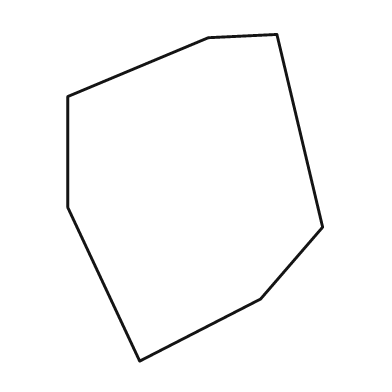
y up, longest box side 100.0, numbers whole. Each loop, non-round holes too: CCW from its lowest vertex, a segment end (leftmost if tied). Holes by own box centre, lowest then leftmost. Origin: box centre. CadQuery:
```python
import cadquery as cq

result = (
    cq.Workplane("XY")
    .moveTo(-17.0, -50.0)
    .lineTo(20.0, -31.0)
    .lineTo(39.0, -9.0)
    .lineTo(25.0, 50.0)
    .lineTo(4.0, 49.0)
    .lineTo(-39.0, 31.0)
    .lineTo(-39.0, -3.0)
    .close()
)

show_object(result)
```